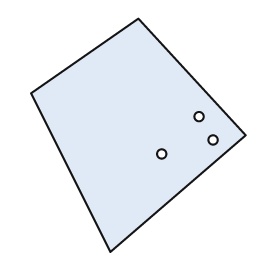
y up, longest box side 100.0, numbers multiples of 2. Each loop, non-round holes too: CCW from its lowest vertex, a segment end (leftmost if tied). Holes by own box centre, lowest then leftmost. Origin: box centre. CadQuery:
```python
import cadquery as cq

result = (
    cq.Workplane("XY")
    .moveTo(-12.0, -50.0)
    .lineTo(46.0, 0.0)
    .lineTo(0.0, 50.0)
    .lineTo(-46.0, 18.0)
    .close()
    .moveTo(10.0, -8.0)
    .circle(2.0)
    .moveTo(32.0, -2.0)
    .circle(2.0)
    .moveTo(26.0, 8.0)
    .circle(2.0)
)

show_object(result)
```